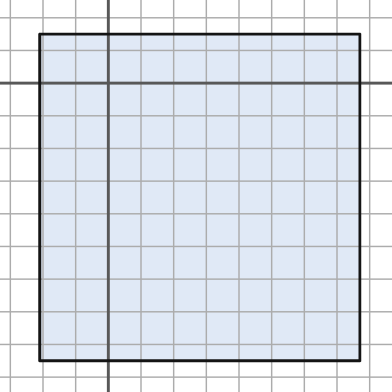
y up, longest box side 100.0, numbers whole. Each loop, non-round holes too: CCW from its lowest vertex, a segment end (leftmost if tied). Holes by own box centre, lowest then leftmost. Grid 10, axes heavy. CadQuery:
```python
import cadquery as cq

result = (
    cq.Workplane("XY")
    .moveTo(-21.0, -85.0)
    .lineTo(77.0, -85.0)
    .lineTo(77.0, 15.0)
    .lineTo(-21.0, 15.0)
    .close()
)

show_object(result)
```